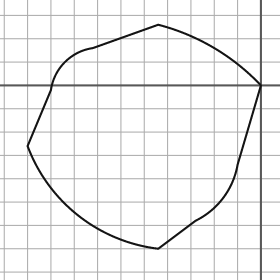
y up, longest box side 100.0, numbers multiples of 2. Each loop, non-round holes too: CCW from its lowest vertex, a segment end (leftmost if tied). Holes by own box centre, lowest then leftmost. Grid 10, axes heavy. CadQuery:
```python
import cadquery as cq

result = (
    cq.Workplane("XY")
    .moveTo(-44.0, -70.0)
    .lineTo(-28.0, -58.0)
    .threePointArc((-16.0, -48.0), (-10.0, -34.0))
    .lineTo(0.0, 0.0)
    .threePointArc((-20.0, 16.0), (-44.0, 26.0))
    .lineTo(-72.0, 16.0)
    .threePointArc((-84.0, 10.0), (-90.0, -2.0))
    .lineTo(-100.0, -26.0)
    .threePointArc((-78.0, -56.0), (-44.0, -70.0))
    .close()
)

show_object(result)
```